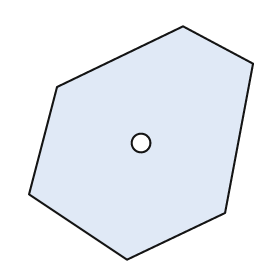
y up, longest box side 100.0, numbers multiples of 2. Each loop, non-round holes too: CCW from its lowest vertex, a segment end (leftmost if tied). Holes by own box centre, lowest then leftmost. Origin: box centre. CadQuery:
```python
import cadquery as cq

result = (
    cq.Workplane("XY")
    .moveTo(-6.0, -50.0)
    .lineTo(36.0, -30.0)
    .lineTo(48.0, 34.0)
    .lineTo(18.0, 50.0)
    .lineTo(-36.0, 24.0)
    .lineTo(-48.0, -22.0)
    .close()
    .moveTo(0.0, 0.0)
    .circle(4.0)
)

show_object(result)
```